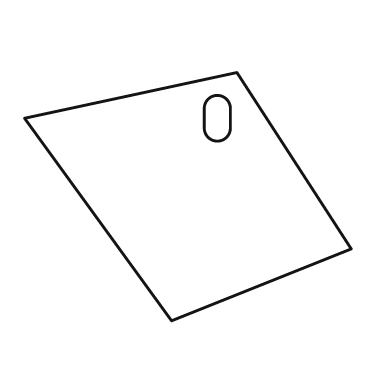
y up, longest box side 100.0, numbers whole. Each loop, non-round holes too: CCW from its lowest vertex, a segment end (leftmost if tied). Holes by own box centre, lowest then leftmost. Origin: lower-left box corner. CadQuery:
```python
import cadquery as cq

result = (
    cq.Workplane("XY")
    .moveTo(45.0, 0.0)
    .lineTo(100.0, 22.0)
    .lineTo(65.0, 76.0)
    .lineTo(0.0, 62.0)
    .close()
    .moveTo(55.0, 59.0)
    .threePointArc((59.0, 55.0), (63.0, 59.0))
    .lineTo(63.0, 65.0)
    .threePointArc((59.0, 69.0), (55.0, 65.0))
    .close()
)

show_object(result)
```